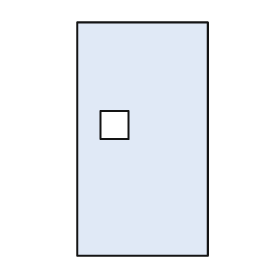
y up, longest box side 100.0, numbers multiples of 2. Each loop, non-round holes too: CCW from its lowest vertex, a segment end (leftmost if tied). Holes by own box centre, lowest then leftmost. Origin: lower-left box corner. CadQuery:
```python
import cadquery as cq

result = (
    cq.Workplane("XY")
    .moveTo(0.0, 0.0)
    .lineTo(56.0, 0.0)
    .lineTo(56.0, 100.0)
    .lineTo(0.0, 100.0)
    .close()
    .moveTo(10.0, 50.0)
    .lineTo(22.0, 50.0)
    .lineTo(22.0, 62.0)
    .lineTo(10.0, 62.0)
    .close()
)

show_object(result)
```